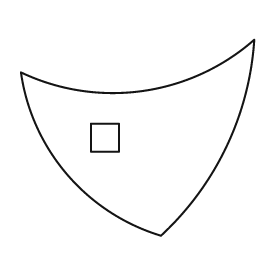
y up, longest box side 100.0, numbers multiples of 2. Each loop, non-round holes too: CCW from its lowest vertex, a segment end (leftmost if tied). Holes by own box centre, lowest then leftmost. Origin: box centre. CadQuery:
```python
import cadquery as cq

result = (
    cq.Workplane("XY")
    .moveTo(10.0, -42.0)
    .threePointArc((38.0, -4.0), (50.0, 42.0))
    .threePointArc((2.0, 20.0), (-50.0, 28.0))
    .threePointArc((-30.0, -16.0), (10.0, -42.0))
    .close()
    .moveTo(-20.0, -6.0)
    .lineTo(-8.0, -6.0)
    .lineTo(-8.0, 6.0)
    .lineTo(-20.0, 6.0)
    .close()
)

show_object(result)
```